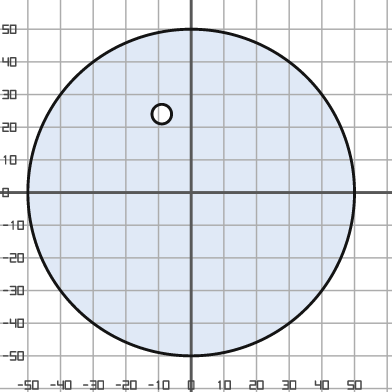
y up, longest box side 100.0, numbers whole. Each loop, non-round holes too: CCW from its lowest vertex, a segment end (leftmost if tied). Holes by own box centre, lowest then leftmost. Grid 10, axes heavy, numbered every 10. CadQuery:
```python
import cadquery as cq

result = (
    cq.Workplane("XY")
    .moveTo(0.0, 0.0)
    .circle(50.0)
    .moveTo(-9.0, 24.0)
    .circle(3.0)
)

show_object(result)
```